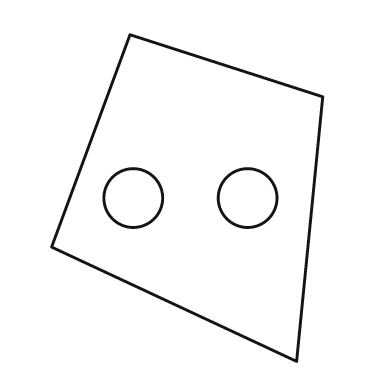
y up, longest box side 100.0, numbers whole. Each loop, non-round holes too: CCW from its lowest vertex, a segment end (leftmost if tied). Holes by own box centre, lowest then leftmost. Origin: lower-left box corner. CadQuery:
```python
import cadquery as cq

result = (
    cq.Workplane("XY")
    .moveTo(75.0, 0.0)
    .lineTo(83.0, 81.0)
    .lineTo(24.0, 100.0)
    .lineTo(0.0, 35.0)
    .close()
    .moveTo(25.0, 50.0)
    .circle(9.0)
    .moveTo(60.0, 50.0)
    .circle(9.0)
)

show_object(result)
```